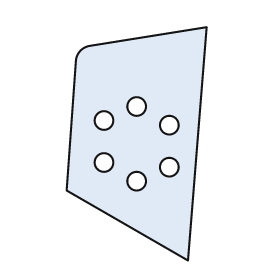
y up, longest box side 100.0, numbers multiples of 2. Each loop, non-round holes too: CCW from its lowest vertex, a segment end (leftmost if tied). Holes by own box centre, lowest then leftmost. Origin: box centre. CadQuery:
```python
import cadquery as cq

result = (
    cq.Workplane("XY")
    .moveTo(22.0, -50.0)
    .lineTo(30.0, 50.0)
    .lineTo(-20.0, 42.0)
    .threePointArc((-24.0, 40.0), (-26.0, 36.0))
    .lineTo(-30.0, -20.0)
    .close()
    .moveTo(0.0, -16.0)
    .circle(4.0)
    .moveTo(14.0, -10.0)
    .circle(4.0)
    .moveTo(-14.0, -8.0)
    .circle(4.0)
    .moveTo(14.0, 8.0)
    .circle(4.0)
    .moveTo(-14.0, 10.0)
    .circle(4.0)
    .moveTo(0.0, 16.0)
    .circle(4.0)
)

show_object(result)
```